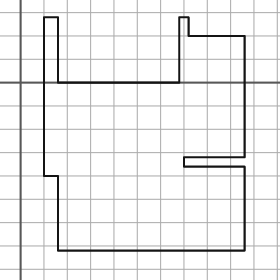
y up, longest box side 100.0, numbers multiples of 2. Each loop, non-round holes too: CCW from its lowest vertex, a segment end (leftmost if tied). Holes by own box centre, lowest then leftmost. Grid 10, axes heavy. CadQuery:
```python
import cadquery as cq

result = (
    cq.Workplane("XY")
    .moveTo(16.0, -72.0)
    .lineTo(96.0, -72.0)
    .lineTo(96.0, -36.0)
    .lineTo(70.0, -36.0)
    .lineTo(70.0, -32.0)
    .lineTo(96.0, -32.0)
    .lineTo(96.0, 20.0)
    .lineTo(72.0, 20.0)
    .lineTo(72.0, 28.0)
    .lineTo(68.0, 28.0)
    .lineTo(68.0, 0.0)
    .lineTo(16.0, 0.0)
    .lineTo(16.0, 28.0)
    .lineTo(10.0, 28.0)
    .lineTo(10.0, -40.0)
    .lineTo(16.0, -40.0)
    .close()
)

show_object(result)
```